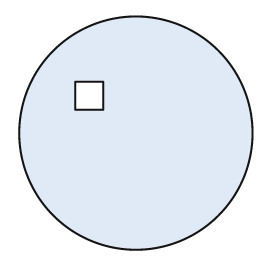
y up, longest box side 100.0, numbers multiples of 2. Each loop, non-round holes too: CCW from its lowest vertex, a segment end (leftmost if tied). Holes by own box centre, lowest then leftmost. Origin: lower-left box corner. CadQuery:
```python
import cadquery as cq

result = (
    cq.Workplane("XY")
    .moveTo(50.0, 50.0)
    .circle(50.0)
    .moveTo(24.0, 60.0)
    .lineTo(36.0, 60.0)
    .lineTo(36.0, 72.0)
    .lineTo(24.0, 72.0)
    .close()
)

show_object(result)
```